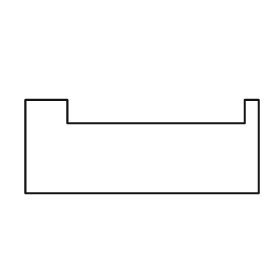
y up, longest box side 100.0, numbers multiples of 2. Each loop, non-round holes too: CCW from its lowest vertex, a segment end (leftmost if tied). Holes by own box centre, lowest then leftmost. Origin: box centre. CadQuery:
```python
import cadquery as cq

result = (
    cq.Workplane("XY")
    .moveTo(-50.0, -20.0)
    .lineTo(50.0, -20.0)
    .lineTo(50.0, 20.0)
    .lineTo(44.0, 20.0)
    .lineTo(44.0, 10.0)
    .lineTo(-32.0, 10.0)
    .lineTo(-32.0, 20.0)
    .lineTo(-50.0, 20.0)
    .close()
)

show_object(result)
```